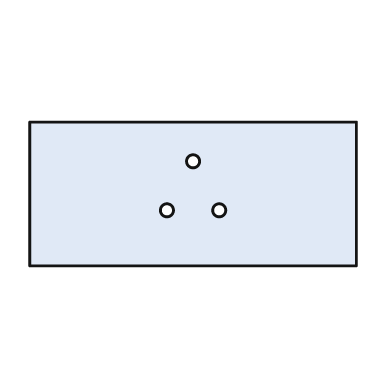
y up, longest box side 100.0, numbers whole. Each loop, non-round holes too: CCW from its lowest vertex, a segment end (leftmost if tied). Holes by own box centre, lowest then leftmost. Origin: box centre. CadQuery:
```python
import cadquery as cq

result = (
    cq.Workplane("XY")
    .moveTo(-50.0, -22.0)
    .lineTo(50.0, -22.0)
    .lineTo(50.0, 22.0)
    .lineTo(-50.0, 22.0)
    .close()
    .moveTo(-8.0, -5.0)
    .circle(2.0)
    .moveTo(8.0, -5.0)
    .circle(2.0)
    .moveTo(0.0, 10.0)
    .circle(2.0)
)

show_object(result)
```